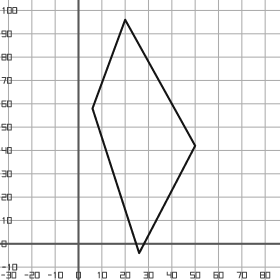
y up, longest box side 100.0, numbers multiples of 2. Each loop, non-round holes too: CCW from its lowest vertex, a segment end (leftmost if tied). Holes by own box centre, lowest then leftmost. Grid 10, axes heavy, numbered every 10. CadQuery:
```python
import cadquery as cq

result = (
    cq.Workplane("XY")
    .moveTo(26.0, -4.0)
    .lineTo(50.0, 42.0)
    .lineTo(20.0, 96.0)
    .lineTo(6.0, 58.0)
    .close()
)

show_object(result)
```